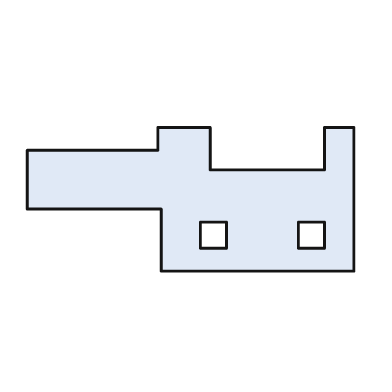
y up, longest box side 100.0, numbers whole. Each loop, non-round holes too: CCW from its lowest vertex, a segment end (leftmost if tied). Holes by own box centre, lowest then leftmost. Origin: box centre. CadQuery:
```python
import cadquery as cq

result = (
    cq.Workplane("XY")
    .moveTo(-9.0, -22.0)
    .lineTo(50.0, -22.0)
    .lineTo(50.0, 22.0)
    .lineTo(41.0, 22.0)
    .lineTo(41.0, 9.0)
    .lineTo(6.0, 9.0)
    .lineTo(6.0, 22.0)
    .lineTo(-10.0, 22.0)
    .lineTo(-10.0, 15.0)
    .lineTo(-50.0, 15.0)
    .lineTo(-50.0, -3.0)
    .lineTo(-9.0, -3.0)
    .close()
    .moveTo(3.0, -15.0)
    .lineTo(11.0, -15.0)
    .lineTo(11.0, -7.0)
    .lineTo(3.0, -7.0)
    .close()
    .moveTo(33.0, -15.0)
    .lineTo(41.0, -15.0)
    .lineTo(41.0, -7.0)
    .lineTo(33.0, -7.0)
    .close()
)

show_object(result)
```